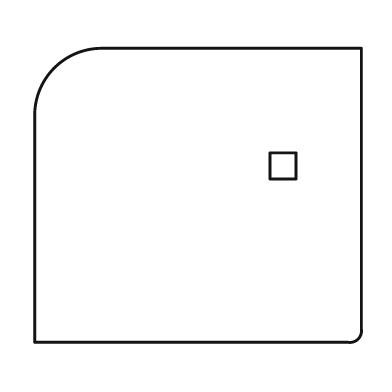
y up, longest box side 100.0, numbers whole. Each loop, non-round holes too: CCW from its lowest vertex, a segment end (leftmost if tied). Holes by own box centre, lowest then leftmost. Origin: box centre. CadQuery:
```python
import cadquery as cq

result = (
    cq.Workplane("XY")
    .moveTo(-50.0, -45.0)
    .lineTo(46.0, -45.0)
    .threePointArc((49.0, -44.0), (50.0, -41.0))
    .lineTo(50.0, 45.0)
    .lineTo(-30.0, 45.0)
    .threePointArc((-44.0, 39.0), (-50.0, 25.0))
    .close()
    .moveTo(22.0, 5.0)
    .lineTo(30.0, 5.0)
    .lineTo(30.0, 13.0)
    .lineTo(22.0, 13.0)
    .close()
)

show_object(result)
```